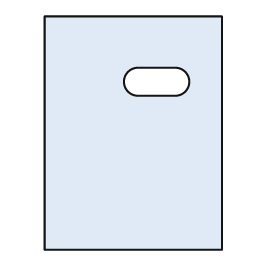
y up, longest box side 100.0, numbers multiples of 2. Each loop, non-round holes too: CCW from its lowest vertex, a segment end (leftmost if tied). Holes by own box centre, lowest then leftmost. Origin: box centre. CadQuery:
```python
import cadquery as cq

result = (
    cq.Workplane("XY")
    .moveTo(-38.0, -50.0)
    .lineTo(38.0, -50.0)
    .lineTo(38.0, 50.0)
    .lineTo(-38.0, 50.0)
    .close()
    .moveTo(2.0, 16.0)
    .lineTo(18.0, 16.0)
    .threePointArc((24.0, 22.0), (18.0, 28.0))
    .lineTo(2.0, 28.0)
    .threePointArc((-4.0, 22.0), (2.0, 16.0))
    .close()
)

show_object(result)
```